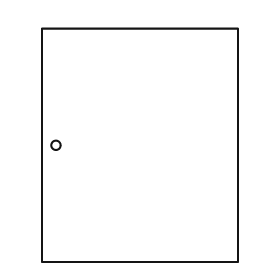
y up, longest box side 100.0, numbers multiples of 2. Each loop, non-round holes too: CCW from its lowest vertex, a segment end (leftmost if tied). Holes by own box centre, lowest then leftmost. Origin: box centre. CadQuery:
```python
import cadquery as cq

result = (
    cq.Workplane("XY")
    .moveTo(-42.0, -50.0)
    .lineTo(42.0, -50.0)
    .lineTo(42.0, 50.0)
    .lineTo(-42.0, 50.0)
    .close()
    .moveTo(-36.0, 0.0)
    .circle(2.0)
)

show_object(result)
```